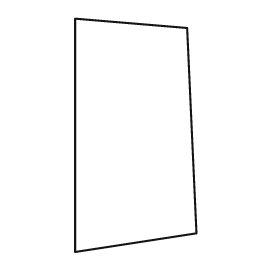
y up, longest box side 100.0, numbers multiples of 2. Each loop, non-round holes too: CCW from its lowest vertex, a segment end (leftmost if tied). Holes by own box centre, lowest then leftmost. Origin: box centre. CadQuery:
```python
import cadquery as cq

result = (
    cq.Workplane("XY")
    .moveTo(-26.0, -50.0)
    .lineTo(26.0, -42.0)
    .lineTo(22.0, 46.0)
    .lineTo(-26.0, 50.0)
    .close()
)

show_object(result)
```